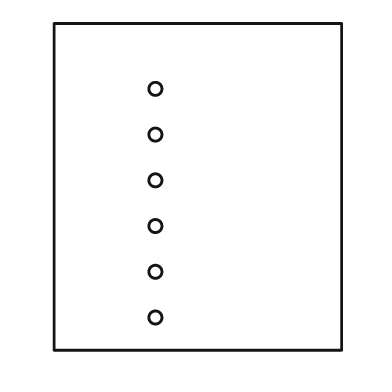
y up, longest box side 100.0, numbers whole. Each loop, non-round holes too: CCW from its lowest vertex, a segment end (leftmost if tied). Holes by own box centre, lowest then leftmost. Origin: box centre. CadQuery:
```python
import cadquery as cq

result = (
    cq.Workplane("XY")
    .moveTo(-44.0, -50.0)
    .lineTo(44.0, -50.0)
    .lineTo(44.0, 50.0)
    .lineTo(-44.0, 50.0)
    .close()
    .moveTo(-13.0, -40.0)
    .circle(2.0)
    .moveTo(-13.0, -26.0)
    .circle(2.0)
    .moveTo(-13.0, -12.0)
    .circle(2.0)
    .moveTo(-13.0, 2.0)
    .circle(2.0)
    .moveTo(-13.0, 16.0)
    .circle(2.0)
    .moveTo(-13.0, 30.0)
    .circle(2.0)
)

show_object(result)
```